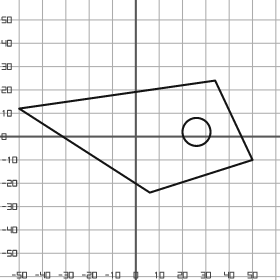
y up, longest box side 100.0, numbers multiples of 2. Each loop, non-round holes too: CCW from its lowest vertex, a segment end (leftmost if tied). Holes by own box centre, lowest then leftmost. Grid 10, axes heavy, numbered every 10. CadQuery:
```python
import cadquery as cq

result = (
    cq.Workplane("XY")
    .moveTo(6.0, -24.0)
    .lineTo(50.0, -10.0)
    .lineTo(34.0, 24.0)
    .lineTo(-50.0, 12.0)
    .close()
    .moveTo(26.0, 2.0)
    .circle(6.0)
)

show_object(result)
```